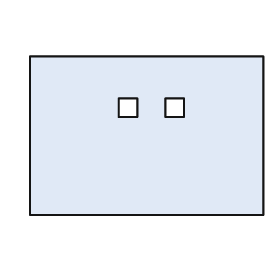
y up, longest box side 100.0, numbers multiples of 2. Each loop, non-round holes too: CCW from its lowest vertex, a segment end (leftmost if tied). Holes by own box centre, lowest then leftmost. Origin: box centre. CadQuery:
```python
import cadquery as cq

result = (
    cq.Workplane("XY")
    .moveTo(-50.0, -34.0)
    .lineTo(50.0, -34.0)
    .lineTo(50.0, 34.0)
    .lineTo(-50.0, 34.0)
    .close()
    .moveTo(-12.0, 8.0)
    .lineTo(-4.0, 8.0)
    .lineTo(-4.0, 16.0)
    .lineTo(-12.0, 16.0)
    .close()
    .moveTo(8.0, 8.0)
    .lineTo(16.0, 8.0)
    .lineTo(16.0, 16.0)
    .lineTo(8.0, 16.0)
    .close()
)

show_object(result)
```